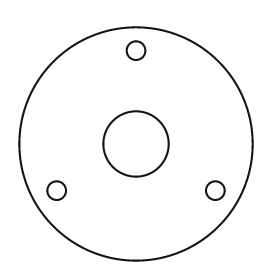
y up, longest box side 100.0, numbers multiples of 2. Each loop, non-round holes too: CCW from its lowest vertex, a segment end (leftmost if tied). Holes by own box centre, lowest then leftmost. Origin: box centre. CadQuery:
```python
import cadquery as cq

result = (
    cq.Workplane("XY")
    .moveTo(0.0, 0.0)
    .circle(50.0)
    .moveTo(-34.0, -20.0)
    .circle(4.0)
    .moveTo(34.0, -20.0)
    .circle(4.0)
    .moveTo(0.0, 0.0)
    .circle(14.0)
    .moveTo(0.0, 40.0)
    .circle(4.0)
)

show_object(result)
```